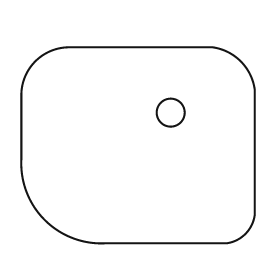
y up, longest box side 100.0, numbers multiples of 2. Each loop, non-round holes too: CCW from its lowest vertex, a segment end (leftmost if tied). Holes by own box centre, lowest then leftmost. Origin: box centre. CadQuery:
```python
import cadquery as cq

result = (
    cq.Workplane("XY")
    .moveTo(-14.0, -42.0)
    .lineTo(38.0, -42.0)
    .threePointArc((46.0, -38.0), (50.0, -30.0))
    .lineTo(50.0, 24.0)
    .threePointArc((44.0, 36.0), (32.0, 42.0))
    .lineTo(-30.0, 42.0)
    .threePointArc((-44.0, 36.0), (-50.0, 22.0))
    .lineTo(-50.0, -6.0)
    .threePointArc((-40.0, -32.0), (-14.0, -42.0))
    .close()
    .moveTo(14.0, 14.0)
    .circle(6.0)
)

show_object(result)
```